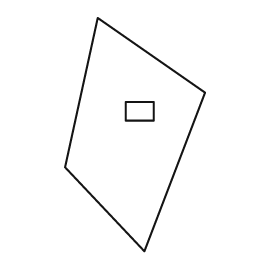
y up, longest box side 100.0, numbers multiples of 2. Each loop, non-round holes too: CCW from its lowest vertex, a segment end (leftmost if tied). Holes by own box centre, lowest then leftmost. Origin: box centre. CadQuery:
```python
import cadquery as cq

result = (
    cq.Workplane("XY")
    .moveTo(4.0, -50.0)
    .lineTo(30.0, 18.0)
    .lineTo(-16.0, 50.0)
    .lineTo(-30.0, -14.0)
    .close()
    .moveTo(-4.0, 6.0)
    .lineTo(8.0, 6.0)
    .lineTo(8.0, 14.0)
    .lineTo(-4.0, 14.0)
    .close()
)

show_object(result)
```